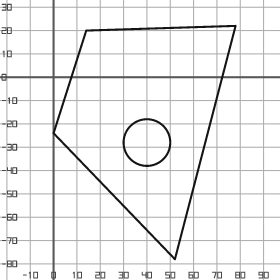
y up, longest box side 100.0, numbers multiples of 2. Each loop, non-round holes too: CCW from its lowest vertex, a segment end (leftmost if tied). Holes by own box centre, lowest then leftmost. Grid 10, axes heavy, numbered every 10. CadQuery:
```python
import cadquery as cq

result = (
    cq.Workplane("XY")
    .moveTo(52.0, -78.0)
    .lineTo(78.0, 22.0)
    .lineTo(14.0, 20.0)
    .lineTo(0.0, -24.0)
    .close()
    .moveTo(40.0, -28.0)
    .circle(10.0)
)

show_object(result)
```